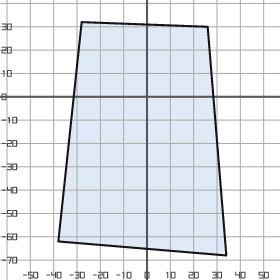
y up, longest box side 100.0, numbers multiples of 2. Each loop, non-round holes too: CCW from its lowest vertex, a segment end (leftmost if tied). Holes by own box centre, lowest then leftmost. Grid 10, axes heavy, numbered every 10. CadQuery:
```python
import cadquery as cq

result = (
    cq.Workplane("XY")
    .moveTo(34.0, -68.0)
    .lineTo(26.0, 30.0)
    .lineTo(-28.0, 32.0)
    .lineTo(-38.0, -62.0)
    .close()
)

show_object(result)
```